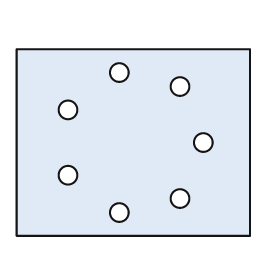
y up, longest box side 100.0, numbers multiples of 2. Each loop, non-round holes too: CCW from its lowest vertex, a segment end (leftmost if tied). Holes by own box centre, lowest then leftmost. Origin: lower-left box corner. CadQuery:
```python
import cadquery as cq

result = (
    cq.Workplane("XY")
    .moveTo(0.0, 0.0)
    .lineTo(100.0, 0.0)
    .lineTo(100.0, 80.0)
    .lineTo(0.0, 80.0)
    .close()
    .moveTo(44.0, 10.0)
    .circle(4.0)
    .moveTo(70.0, 16.0)
    .circle(4.0)
    .moveTo(22.0, 26.0)
    .circle(4.0)
    .moveTo(80.0, 40.0)
    .circle(4.0)
    .moveTo(22.0, 54.0)
    .circle(4.0)
    .moveTo(70.0, 64.0)
    .circle(4.0)
    .moveTo(44.0, 70.0)
    .circle(4.0)
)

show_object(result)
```